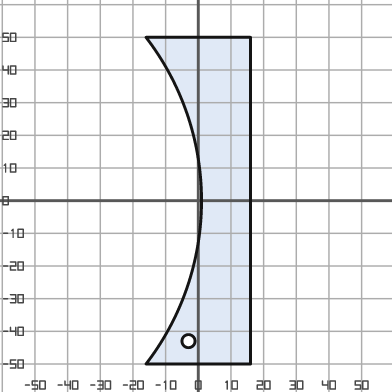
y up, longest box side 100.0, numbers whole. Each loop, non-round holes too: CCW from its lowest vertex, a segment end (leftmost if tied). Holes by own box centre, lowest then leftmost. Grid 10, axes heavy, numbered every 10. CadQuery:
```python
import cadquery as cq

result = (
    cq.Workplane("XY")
    .moveTo(-16.0, -50.0)
    .lineTo(16.0, -50.0)
    .lineTo(16.0, 50.0)
    .lineTo(-16.0, 50.0)
    .threePointArc((1.0, 0.0), (-16.0, -50.0))
    .close()
    .moveTo(-3.0, -43.0)
    .circle(2.0)
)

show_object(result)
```